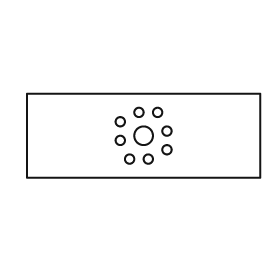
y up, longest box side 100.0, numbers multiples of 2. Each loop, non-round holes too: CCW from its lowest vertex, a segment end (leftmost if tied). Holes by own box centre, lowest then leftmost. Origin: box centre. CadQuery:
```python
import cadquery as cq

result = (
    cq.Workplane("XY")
    .moveTo(-50.0, -18.0)
    .lineTo(50.0, -18.0)
    .lineTo(50.0, 18.0)
    .lineTo(-50.0, 18.0)
    .close()
    .moveTo(-6.0, -10.0)
    .circle(2.0)
    .moveTo(2.0, -10.0)
    .circle(2.0)
    .moveTo(10.0, -6.0)
    .circle(2.0)
    .moveTo(-10.0, -2.0)
    .circle(2.0)
    .moveTo(0.0, 0.0)
    .circle(4.0)
    .moveTo(10.0, 2.0)
    .circle(2.0)
    .moveTo(-10.0, 6.0)
    .circle(2.0)
    .moveTo(-2.0, 10.0)
    .circle(2.0)
    .moveTo(6.0, 10.0)
    .circle(2.0)
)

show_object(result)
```